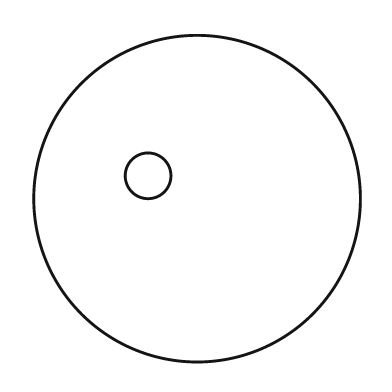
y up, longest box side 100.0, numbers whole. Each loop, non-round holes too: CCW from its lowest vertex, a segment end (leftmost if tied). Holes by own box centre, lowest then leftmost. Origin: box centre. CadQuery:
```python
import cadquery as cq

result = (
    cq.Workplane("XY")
    .moveTo(0.0, 0.0)
    .circle(50.0)
    .moveTo(-15.0, 7.0)
    .circle(7.0)
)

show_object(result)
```